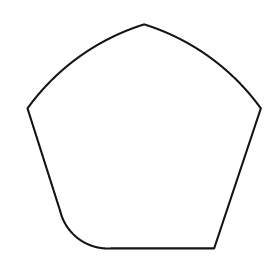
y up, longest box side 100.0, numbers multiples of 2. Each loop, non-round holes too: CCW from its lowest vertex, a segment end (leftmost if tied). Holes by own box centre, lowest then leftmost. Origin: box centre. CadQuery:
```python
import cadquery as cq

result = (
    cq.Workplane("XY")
    .moveTo(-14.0, -48.0)
    .lineTo(30.0, -48.0)
    .lineTo(50.0, 12.0)
    .threePointArc((28.0, 34.0), (0.0, 48.0))
    .threePointArc((-28.0, 34.0), (-50.0, 12.0))
    .lineTo(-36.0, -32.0)
    .threePointArc((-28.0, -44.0), (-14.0, -48.0))
    .close()
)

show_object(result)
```